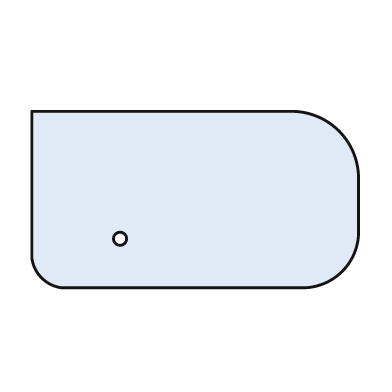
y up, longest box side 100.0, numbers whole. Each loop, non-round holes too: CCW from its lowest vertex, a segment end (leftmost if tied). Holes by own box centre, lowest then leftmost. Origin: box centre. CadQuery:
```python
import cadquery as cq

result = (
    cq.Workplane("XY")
    .moveTo(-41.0, -27.0)
    .lineTo(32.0, -27.0)
    .threePointArc((45.0, -22.0), (50.0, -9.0))
    .lineTo(50.0, 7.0)
    .threePointArc((44.0, 21.0), (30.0, 27.0))
    .lineTo(-50.0, 27.0)
    .lineTo(-50.0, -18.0)
    .threePointArc((-47.0, -24.0), (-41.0, -27.0))
    .close()
    .moveTo(-23.0, -12.0)
    .circle(2.0)
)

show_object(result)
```